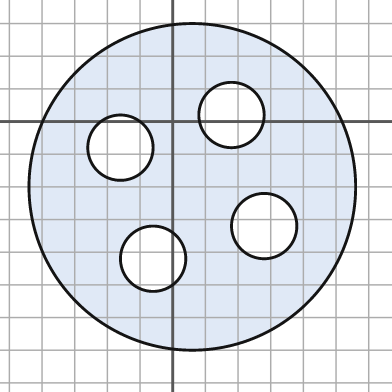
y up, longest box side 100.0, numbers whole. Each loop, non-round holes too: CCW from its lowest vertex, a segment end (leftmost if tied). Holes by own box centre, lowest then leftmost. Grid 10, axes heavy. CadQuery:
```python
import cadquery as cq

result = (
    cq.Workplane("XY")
    .moveTo(6.0, -20.0)
    .circle(50.0)
    .moveTo(-6.0, -42.0)
    .circle(10.0)
    .moveTo(28.0, -32.0)
    .circle(10.0)
    .moveTo(-16.0, -8.0)
    .circle(10.0)
    .moveTo(18.0, 2.0)
    .circle(10.0)
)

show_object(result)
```